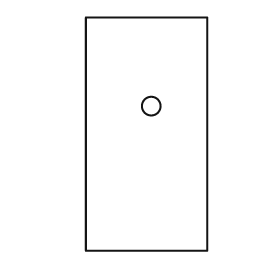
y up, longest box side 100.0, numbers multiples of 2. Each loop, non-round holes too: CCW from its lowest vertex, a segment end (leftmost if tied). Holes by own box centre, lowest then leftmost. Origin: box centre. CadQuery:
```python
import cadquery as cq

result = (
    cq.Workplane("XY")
    .moveTo(-26.0, -50.0)
    .lineTo(26.0, -50.0)
    .lineTo(26.0, 50.0)
    .lineTo(-26.0, 50.0)
    .close()
    .moveTo(2.0, 12.0)
    .circle(4.0)
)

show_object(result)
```